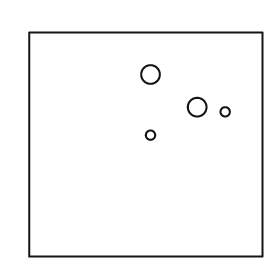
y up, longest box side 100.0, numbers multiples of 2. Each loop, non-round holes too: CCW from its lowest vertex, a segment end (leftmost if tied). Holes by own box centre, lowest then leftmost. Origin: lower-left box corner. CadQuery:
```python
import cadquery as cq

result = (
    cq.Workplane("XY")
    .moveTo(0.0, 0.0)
    .lineTo(100.0, 0.0)
    .lineTo(100.0, 96.0)
    .lineTo(0.0, 96.0)
    .close()
    .moveTo(52.0, 52.0)
    .circle(2.0)
    .moveTo(84.0, 62.0)
    .circle(2.0)
    .moveTo(72.0, 64.0)
    .circle(4.0)
    .moveTo(52.0, 78.0)
    .circle(4.0)
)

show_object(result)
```